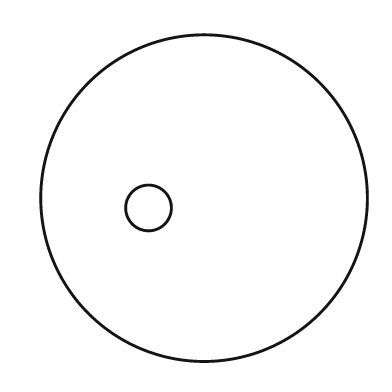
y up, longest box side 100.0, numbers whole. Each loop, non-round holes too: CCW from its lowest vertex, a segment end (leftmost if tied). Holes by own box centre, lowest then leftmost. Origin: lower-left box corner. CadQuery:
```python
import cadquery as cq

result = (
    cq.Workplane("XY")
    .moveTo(50.0, 50.0)
    .circle(50.0)
    .moveTo(33.0, 47.0)
    .circle(7.0)
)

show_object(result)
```